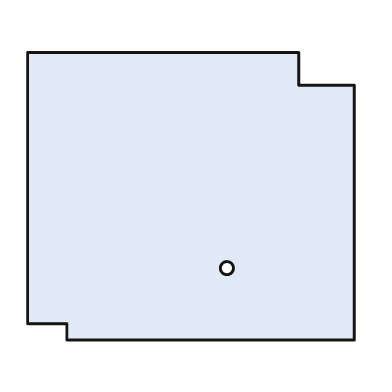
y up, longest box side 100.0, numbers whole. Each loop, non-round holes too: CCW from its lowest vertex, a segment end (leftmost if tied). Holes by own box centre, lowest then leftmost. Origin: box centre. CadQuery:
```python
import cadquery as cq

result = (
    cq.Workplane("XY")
    .moveTo(-38.0, -44.0)
    .lineTo(50.0, -44.0)
    .lineTo(50.0, 34.0)
    .lineTo(33.0, 34.0)
    .lineTo(33.0, 44.0)
    .lineTo(-50.0, 44.0)
    .lineTo(-50.0, -39.0)
    .lineTo(-38.0, -39.0)
    .close()
    .moveTo(11.0, -22.0)
    .circle(2.0)
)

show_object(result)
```